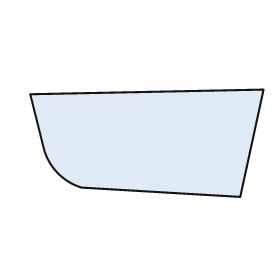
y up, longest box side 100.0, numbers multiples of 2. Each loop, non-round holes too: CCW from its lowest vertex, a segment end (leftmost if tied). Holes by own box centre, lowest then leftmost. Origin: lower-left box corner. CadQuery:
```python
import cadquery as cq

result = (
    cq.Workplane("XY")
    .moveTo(90.0, 0.0)
    .lineTo(100.0, 46.0)
    .lineTo(0.0, 44.0)
    .lineTo(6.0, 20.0)
    .threePointArc((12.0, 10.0), (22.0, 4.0))
    .close()
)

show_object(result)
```